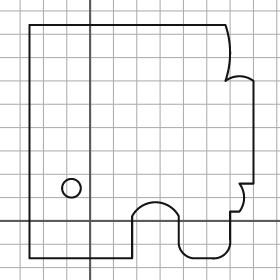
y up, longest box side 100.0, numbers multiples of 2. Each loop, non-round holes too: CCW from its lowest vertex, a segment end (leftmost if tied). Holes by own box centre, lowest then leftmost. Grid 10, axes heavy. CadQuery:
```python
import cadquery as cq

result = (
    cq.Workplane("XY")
    .moveTo(-26.0, -16.0)
    .lineTo(18.0, -16.0)
    .lineTo(18.0, 2.0)
    .threePointArc((28.0, 8.0), (38.0, 2.0))
    .lineTo(38.0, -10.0)
    .threePointArc((40.0, -14.0), (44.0, -16.0))
    .lineTo(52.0, -16.0)
    .threePointArc((58.0, -14.0), (60.0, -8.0))
    .lineTo(60.0, 4.0)
    .lineTo(64.0, 4.0)
    .threePointArc((66.0, 10.0), (64.0, 16.0))
    .lineTo(70.0, 16.0)
    .lineTo(70.0, 60.0)
    .threePointArc((64.0, 62.0), (58.0, 60.0))
    .threePointArc((60.0, 72.0), (58.0, 84.0))
    .lineTo(-26.0, 84.0)
    .close()
    .moveTo(-8.0, 14.0)
    .circle(4.0)
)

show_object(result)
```